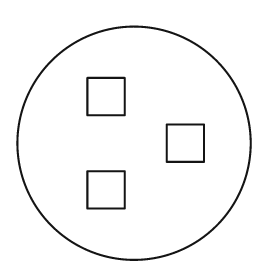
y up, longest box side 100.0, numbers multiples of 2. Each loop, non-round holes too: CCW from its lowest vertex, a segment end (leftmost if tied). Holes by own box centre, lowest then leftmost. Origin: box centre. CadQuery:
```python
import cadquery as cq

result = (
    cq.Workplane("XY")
    .moveTo(0.0, 0.0)
    .circle(50.0)
    .moveTo(-20.0, -28.0)
    .lineTo(-4.0, -28.0)
    .lineTo(-4.0, -12.0)
    .lineTo(-20.0, -12.0)
    .close()
    .moveTo(14.0, -8.0)
    .lineTo(30.0, -8.0)
    .lineTo(30.0, 8.0)
    .lineTo(14.0, 8.0)
    .close()
    .moveTo(-20.0, 12.0)
    .lineTo(-4.0, 12.0)
    .lineTo(-4.0, 28.0)
    .lineTo(-20.0, 28.0)
    .close()
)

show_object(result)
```